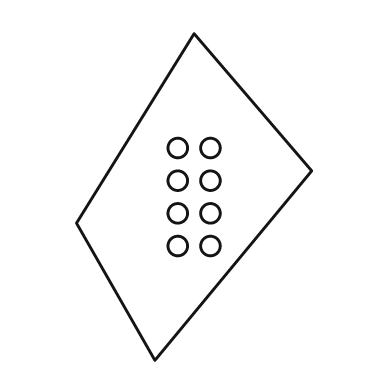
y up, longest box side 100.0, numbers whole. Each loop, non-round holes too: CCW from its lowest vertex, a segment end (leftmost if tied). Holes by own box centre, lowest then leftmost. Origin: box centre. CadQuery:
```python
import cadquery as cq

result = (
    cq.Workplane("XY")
    .moveTo(-12.0, -50.0)
    .lineTo(36.0, 8.0)
    .lineTo(0.0, 50.0)
    .lineTo(-36.0, -8.0)
    .close()
    .moveTo(-5.0, -15.0)
    .circle(3.0)
    .moveTo(5.0, -15.0)
    .circle(3.0)
    .moveTo(-5.0, -5.0)
    .circle(3.0)
    .moveTo(5.0, -5.0)
    .circle(3.0)
    .moveTo(-5.0, 5.0)
    .circle(3.0)
    .moveTo(5.0, 5.0)
    .circle(3.0)
    .moveTo(-5.0, 15.0)
    .circle(3.0)
    .moveTo(5.0, 15.0)
    .circle(3.0)
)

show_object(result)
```